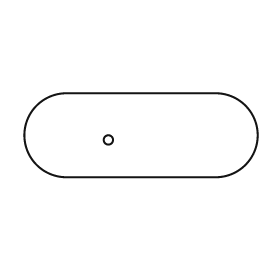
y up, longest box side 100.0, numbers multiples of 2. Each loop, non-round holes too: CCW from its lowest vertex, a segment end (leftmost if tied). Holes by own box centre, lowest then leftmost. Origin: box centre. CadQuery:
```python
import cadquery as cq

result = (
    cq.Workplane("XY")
    .moveTo(-32.0, -18.0)
    .lineTo(32.0, -18.0)
    .threePointArc((50.0, 0.0), (32.0, 18.0))
    .lineTo(-32.0, 18.0)
    .threePointArc((-50.0, 0.0), (-32.0, -18.0))
    .close()
    .moveTo(-14.0, -2.0)
    .circle(2.0)
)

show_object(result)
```